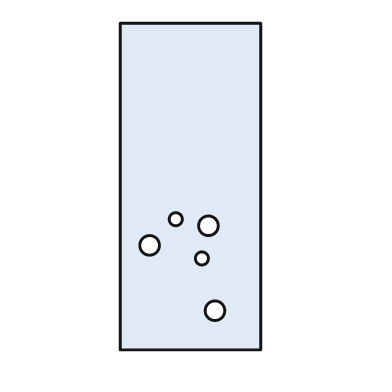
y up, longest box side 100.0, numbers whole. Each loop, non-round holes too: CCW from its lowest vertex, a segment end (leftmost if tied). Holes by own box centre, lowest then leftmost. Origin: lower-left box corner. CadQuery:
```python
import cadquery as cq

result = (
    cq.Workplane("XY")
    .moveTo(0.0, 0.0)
    .lineTo(43.0, 0.0)
    .lineTo(43.0, 100.0)
    .lineTo(0.0, 100.0)
    .close()
    .moveTo(29.0, 12.0)
    .circle(3.0)
    .moveTo(25.0, 28.0)
    .circle(2.0)
    .moveTo(9.0, 32.0)
    .circle(3.0)
    .moveTo(27.0, 38.0)
    .circle(3.0)
    .moveTo(17.0, 40.0)
    .circle(2.0)
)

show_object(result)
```